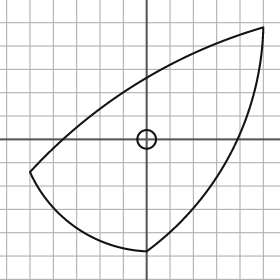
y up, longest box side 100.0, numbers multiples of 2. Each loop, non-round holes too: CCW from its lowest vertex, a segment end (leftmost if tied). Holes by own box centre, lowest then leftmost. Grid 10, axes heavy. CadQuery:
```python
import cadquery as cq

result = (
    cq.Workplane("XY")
    .moveTo(0.0, -48.0)
    .threePointArc((36.0, -6.0), (50.0, 48.0))
    .threePointArc((-4.0, 24.0), (-50.0, -14.0))
    .threePointArc((-30.0, -38.0), (0.0, -48.0))
    .close()
    .moveTo(0.0, 0.0)
    .circle(4.0)
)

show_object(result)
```